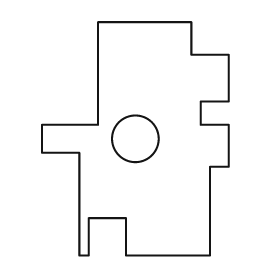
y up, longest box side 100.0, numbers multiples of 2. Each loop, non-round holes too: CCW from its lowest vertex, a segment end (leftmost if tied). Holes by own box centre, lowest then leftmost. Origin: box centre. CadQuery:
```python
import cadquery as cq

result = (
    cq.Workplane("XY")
    .moveTo(-24.0, -50.0)
    .lineTo(-20.0, -50.0)
    .lineTo(-20.0, -34.0)
    .lineTo(-4.0, -34.0)
    .lineTo(-4.0, -50.0)
    .lineTo(32.0, -50.0)
    .lineTo(32.0, -12.0)
    .lineTo(40.0, -12.0)
    .lineTo(40.0, 6.0)
    .lineTo(28.0, 6.0)
    .lineTo(28.0, 16.0)
    .lineTo(40.0, 16.0)
    .lineTo(40.0, 36.0)
    .lineTo(24.0, 36.0)
    .lineTo(24.0, 50.0)
    .lineTo(-16.0, 50.0)
    .lineTo(-16.0, 6.0)
    .lineTo(-40.0, 6.0)
    .lineTo(-40.0, -6.0)
    .lineTo(-24.0, -6.0)
    .close()
    .moveTo(0.0, 0.0)
    .circle(10.0)
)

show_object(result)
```